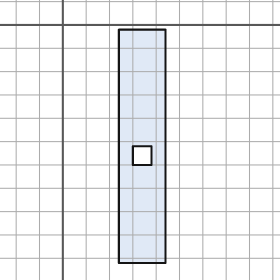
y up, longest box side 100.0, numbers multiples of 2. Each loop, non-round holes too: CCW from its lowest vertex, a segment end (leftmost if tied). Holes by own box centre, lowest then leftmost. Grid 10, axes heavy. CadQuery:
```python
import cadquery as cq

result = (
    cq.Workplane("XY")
    .moveTo(24.0, -102.0)
    .lineTo(44.0, -102.0)
    .lineTo(44.0, -2.0)
    .lineTo(24.0, -2.0)
    .close()
    .moveTo(30.0, -60.0)
    .lineTo(38.0, -60.0)
    .lineTo(38.0, -52.0)
    .lineTo(30.0, -52.0)
    .close()
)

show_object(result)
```